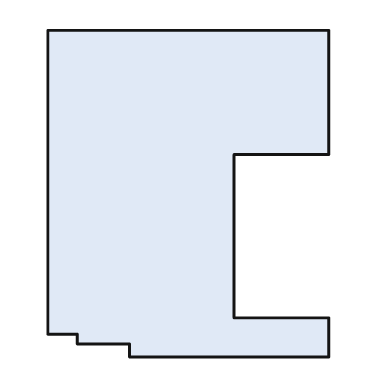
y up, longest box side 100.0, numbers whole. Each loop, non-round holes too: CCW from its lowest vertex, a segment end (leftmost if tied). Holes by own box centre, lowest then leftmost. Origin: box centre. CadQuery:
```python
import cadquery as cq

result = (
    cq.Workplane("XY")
    .moveTo(-18.0, -50.0)
    .lineTo(43.0, -50.0)
    .lineTo(43.0, -38.0)
    .lineTo(14.0, -38.0)
    .lineTo(14.0, 12.0)
    .lineTo(43.0, 12.0)
    .lineTo(43.0, 50.0)
    .lineTo(-43.0, 50.0)
    .lineTo(-43.0, -43.0)
    .lineTo(-34.0, -43.0)
    .lineTo(-34.0, -46.0)
    .lineTo(-18.0, -46.0)
    .close()
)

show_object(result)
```